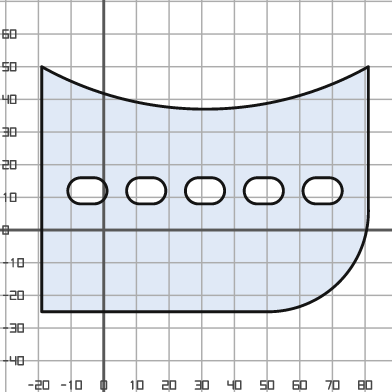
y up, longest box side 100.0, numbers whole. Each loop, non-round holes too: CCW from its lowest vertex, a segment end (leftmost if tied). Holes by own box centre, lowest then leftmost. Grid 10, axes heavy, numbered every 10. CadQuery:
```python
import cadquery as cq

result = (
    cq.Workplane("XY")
    .moveTo(-19.0, -25.0)
    .lineTo(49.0, -25.0)
    .threePointArc((72.0, -16.0), (81.0, 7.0))
    .lineTo(81.0, 50.0)
    .threePointArc((31.0, 37.0), (-19.0, 50.0))
    .close()
    .moveTo(-7.0, 8.0)
    .lineTo(-3.0, 8.0)
    .threePointArc((1.0, 12.0), (-3.0, 16.0))
    .lineTo(-7.0, 16.0)
    .threePointArc((-11.0, 12.0), (-7.0, 8.0))
    .close()
    .moveTo(11.0, 8.0)
    .lineTo(15.0, 8.0)
    .threePointArc((19.0, 12.0), (15.0, 16.0))
    .lineTo(11.0, 16.0)
    .threePointArc((7.0, 12.0), (11.0, 8.0))
    .close()
    .moveTo(29.0, 8.0)
    .lineTo(33.0, 8.0)
    .threePointArc((37.0, 12.0), (33.0, 16.0))
    .lineTo(29.0, 16.0)
    .threePointArc((25.0, 12.0), (29.0, 8.0))
    .close()
    .moveTo(47.0, 8.0)
    .lineTo(51.0, 8.0)
    .threePointArc((55.0, 12.0), (51.0, 16.0))
    .lineTo(47.0, 16.0)
    .threePointArc((43.0, 12.0), (47.0, 8.0))
    .close()
    .moveTo(65.0, 8.0)
    .lineTo(69.0, 8.0)
    .threePointArc((73.0, 12.0), (69.0, 16.0))
    .lineTo(65.0, 16.0)
    .threePointArc((61.0, 12.0), (65.0, 8.0))
    .close()
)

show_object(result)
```